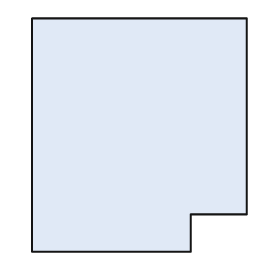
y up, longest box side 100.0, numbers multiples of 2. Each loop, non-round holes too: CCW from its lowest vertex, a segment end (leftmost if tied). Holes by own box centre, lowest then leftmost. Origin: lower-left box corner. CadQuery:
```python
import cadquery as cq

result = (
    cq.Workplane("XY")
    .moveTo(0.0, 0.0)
    .lineTo(68.0, 0.0)
    .lineTo(68.0, 16.0)
    .lineTo(92.0, 16.0)
    .lineTo(92.0, 100.0)
    .lineTo(0.0, 100.0)
    .close()
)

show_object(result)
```